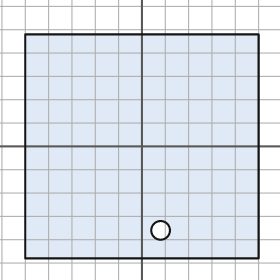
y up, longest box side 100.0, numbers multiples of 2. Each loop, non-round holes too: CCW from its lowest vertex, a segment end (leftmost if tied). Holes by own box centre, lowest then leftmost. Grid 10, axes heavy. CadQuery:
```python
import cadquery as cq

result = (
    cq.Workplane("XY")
    .moveTo(-50.0, -48.0)
    .lineTo(50.0, -48.0)
    .lineTo(50.0, 48.0)
    .lineTo(-50.0, 48.0)
    .close()
    .moveTo(8.0, -36.0)
    .circle(4.0)
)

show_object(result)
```